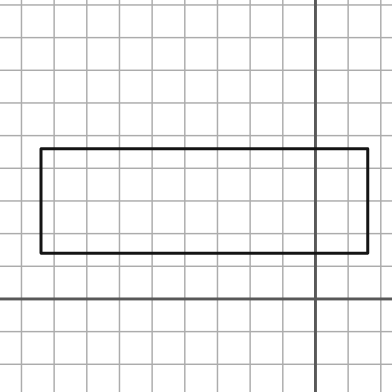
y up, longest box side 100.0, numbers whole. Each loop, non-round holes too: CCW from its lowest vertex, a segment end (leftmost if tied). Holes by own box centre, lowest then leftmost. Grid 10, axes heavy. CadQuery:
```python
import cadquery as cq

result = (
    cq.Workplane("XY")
    .moveTo(-84.0, 14.0)
    .lineTo(16.0, 14.0)
    .lineTo(16.0, 46.0)
    .lineTo(-84.0, 46.0)
    .close()
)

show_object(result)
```